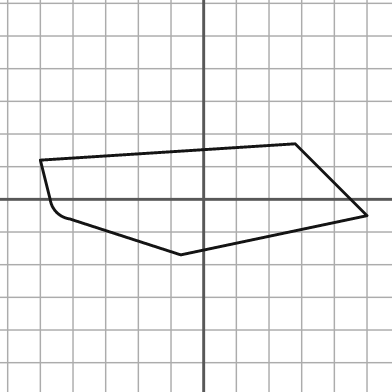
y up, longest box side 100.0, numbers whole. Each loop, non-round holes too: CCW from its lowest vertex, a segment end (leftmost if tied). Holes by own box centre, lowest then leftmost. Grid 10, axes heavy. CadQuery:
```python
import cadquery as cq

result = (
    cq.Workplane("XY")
    .moveTo(-7.0, -17.0)
    .lineTo(50.0, -5.0)
    .lineTo(28.0, 17.0)
    .lineTo(-50.0, 12.0)
    .lineTo(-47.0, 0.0)
    .threePointArc((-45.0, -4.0), (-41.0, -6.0))
    .close()
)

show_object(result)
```